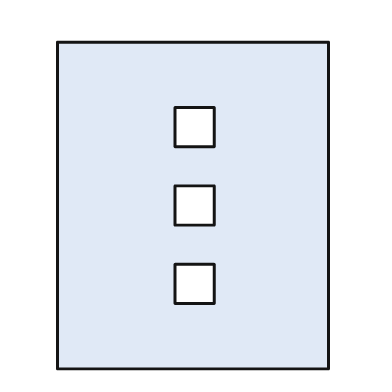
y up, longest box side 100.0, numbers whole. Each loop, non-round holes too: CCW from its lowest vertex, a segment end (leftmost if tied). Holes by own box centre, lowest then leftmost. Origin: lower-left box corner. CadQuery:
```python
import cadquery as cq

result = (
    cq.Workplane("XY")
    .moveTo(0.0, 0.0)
    .lineTo(83.0, 0.0)
    .lineTo(83.0, 100.0)
    .lineTo(0.0, 100.0)
    .close()
    .moveTo(36.0, 20.0)
    .lineTo(48.0, 20.0)
    .lineTo(48.0, 32.0)
    .lineTo(36.0, 32.0)
    .close()
    .moveTo(36.0, 44.0)
    .lineTo(48.0, 44.0)
    .lineTo(48.0, 56.0)
    .lineTo(36.0, 56.0)
    .close()
    .moveTo(36.0, 68.0)
    .lineTo(48.0, 68.0)
    .lineTo(48.0, 80.0)
    .lineTo(36.0, 80.0)
    .close()
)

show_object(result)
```